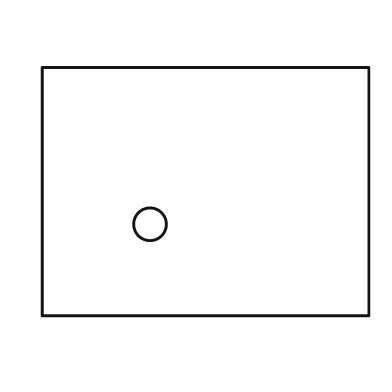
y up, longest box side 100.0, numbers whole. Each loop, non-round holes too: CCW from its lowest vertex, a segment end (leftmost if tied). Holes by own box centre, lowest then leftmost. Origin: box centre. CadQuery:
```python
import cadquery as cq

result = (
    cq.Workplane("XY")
    .moveTo(-50.0, -38.0)
    .lineTo(50.0, -38.0)
    .lineTo(50.0, 38.0)
    .lineTo(-50.0, 38.0)
    .close()
    .moveTo(-17.0, -10.0)
    .circle(5.0)
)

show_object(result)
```